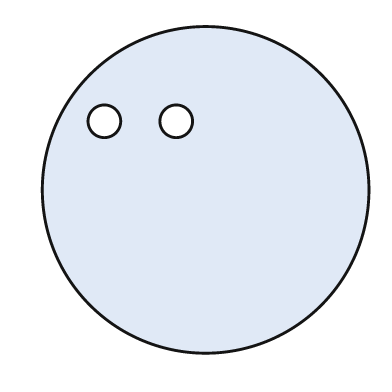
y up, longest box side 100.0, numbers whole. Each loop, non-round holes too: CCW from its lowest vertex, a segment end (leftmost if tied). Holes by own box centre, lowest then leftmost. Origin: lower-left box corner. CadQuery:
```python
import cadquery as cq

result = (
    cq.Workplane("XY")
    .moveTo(50.0, 50.0)
    .circle(50.0)
    .moveTo(19.0, 71.0)
    .circle(5.0)
    .moveTo(41.0, 71.0)
    .circle(5.0)
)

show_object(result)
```